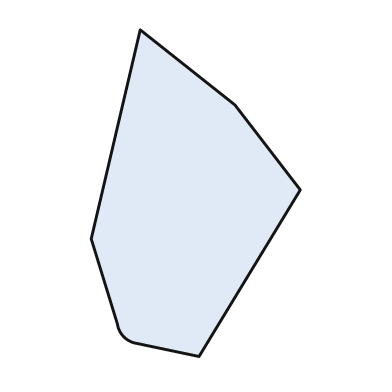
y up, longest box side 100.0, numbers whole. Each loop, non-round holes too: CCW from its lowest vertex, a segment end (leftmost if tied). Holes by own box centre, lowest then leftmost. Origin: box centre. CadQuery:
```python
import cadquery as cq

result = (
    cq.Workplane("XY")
    .moveTo(1.0, -50.0)
    .lineTo(32.0, 1.0)
    .lineTo(12.0, 27.0)
    .lineTo(-17.0, 50.0)
    .lineTo(-32.0, -14.0)
    .lineTo(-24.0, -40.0)
    .threePointArc((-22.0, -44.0), (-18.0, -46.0))
    .close()
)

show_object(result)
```